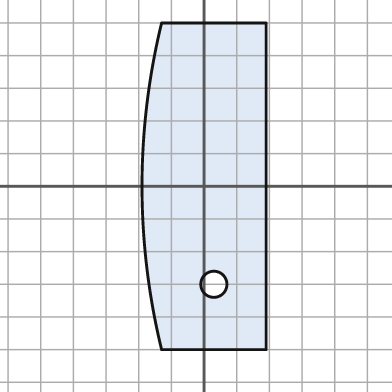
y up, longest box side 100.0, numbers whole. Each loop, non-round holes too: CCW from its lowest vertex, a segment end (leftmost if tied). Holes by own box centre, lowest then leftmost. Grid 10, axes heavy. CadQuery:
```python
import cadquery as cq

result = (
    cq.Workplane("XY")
    .moveTo(-13.0, -50.0)
    .lineTo(19.0, -50.0)
    .lineTo(19.0, 50.0)
    .lineTo(-13.0, 50.0)
    .threePointArc((-19.0, 0.0), (-13.0, -50.0))
    .close()
    .moveTo(3.0, -30.0)
    .circle(4.0)
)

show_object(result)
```